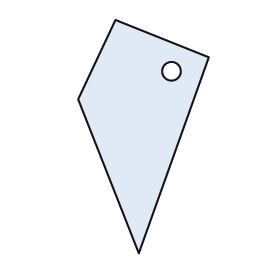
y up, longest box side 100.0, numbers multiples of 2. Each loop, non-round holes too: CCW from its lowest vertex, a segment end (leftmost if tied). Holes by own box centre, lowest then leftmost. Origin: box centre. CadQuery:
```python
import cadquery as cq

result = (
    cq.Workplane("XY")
    .moveTo(-2.0, -50.0)
    .lineTo(28.0, 34.0)
    .lineTo(-12.0, 50.0)
    .lineTo(-28.0, 16.0)
    .close()
    .moveTo(12.0, 28.0)
    .circle(4.0)
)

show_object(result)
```